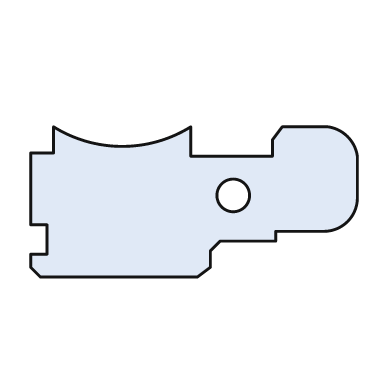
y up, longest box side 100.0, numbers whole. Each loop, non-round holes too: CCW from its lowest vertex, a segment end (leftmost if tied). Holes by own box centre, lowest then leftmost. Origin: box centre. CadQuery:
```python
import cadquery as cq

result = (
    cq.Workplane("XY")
    .moveTo(-47.0, -23.0)
    .lineTo(1.0, -23.0)
    .lineTo(5.0, -20.0)
    .lineTo(5.0, -15.0)
    .lineTo(8.0, -12.0)
    .lineTo(25.0, -12.0)
    .lineTo(25.0, -9.0)
    .lineTo(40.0, -9.0)
    .threePointArc((47.0, -6.0), (50.0, 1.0))
    .lineTo(50.0, 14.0)
    .threePointArc((47.0, 20.0), (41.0, 23.0))
    .lineTo(27.0, 23.0)
    .lineTo(24.0, 19.0)
    .lineTo(24.0, 14.0)
    .lineTo(-1.0, 14.0)
    .lineTo(-1.0, 23.0)
    .threePointArc((-22.0, 17.0), (-43.0, 23.0))
    .lineTo(-43.0, 15.0)
    .lineTo(-50.0, 15.0)
    .lineTo(-50.0, -7.0)
    .lineTo(-45.0, -7.0)
    .lineTo(-45.0, -16.0)
    .lineTo(-50.0, -16.0)
    .lineTo(-50.0, -20.0)
    .close()
    .moveTo(12.0, 2.0)
    .circle(5.0)
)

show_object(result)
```